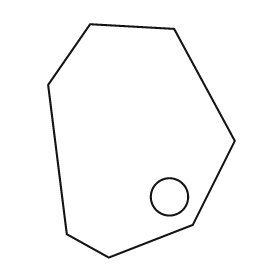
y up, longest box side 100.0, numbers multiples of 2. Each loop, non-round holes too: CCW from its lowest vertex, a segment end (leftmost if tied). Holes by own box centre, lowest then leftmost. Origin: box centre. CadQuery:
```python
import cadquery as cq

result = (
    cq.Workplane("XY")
    .moveTo(-14.0, -50.0)
    .lineTo(22.0, -36.0)
    .lineTo(40.0, 0.0)
    .lineTo(14.0, 48.0)
    .lineTo(-22.0, 50.0)
    .lineTo(-40.0, 24.0)
    .lineTo(-32.0, -40.0)
    .close()
    .moveTo(12.0, -24.0)
    .circle(8.0)
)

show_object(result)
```